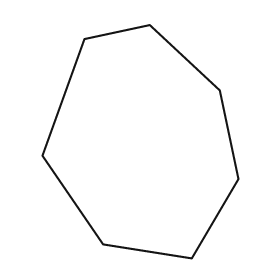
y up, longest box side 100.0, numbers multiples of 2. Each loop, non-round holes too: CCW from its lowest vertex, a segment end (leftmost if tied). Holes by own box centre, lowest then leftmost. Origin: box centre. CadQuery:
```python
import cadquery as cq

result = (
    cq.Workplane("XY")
    .moveTo(22.0, -50.0)
    .lineTo(42.0, -16.0)
    .lineTo(34.0, 22.0)
    .lineTo(4.0, 50.0)
    .lineTo(-24.0, 44.0)
    .lineTo(-42.0, -6.0)
    .lineTo(-16.0, -44.0)
    .close()
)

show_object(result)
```